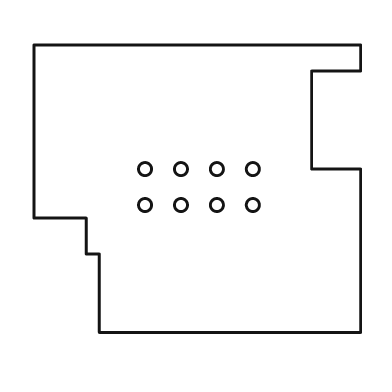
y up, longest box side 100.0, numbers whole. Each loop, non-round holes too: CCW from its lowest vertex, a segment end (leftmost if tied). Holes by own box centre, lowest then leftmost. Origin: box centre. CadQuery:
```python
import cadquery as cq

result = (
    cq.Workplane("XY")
    .moveTo(-30.0, -44.0)
    .lineTo(50.0, -44.0)
    .lineTo(50.0, 6.0)
    .lineTo(35.0, 6.0)
    .lineTo(35.0, 36.0)
    .lineTo(50.0, 36.0)
    .lineTo(50.0, 44.0)
    .lineTo(-50.0, 44.0)
    .lineTo(-50.0, -9.0)
    .lineTo(-34.0, -9.0)
    .lineTo(-34.0, -20.0)
    .lineTo(-30.0, -20.0)
    .close()
    .moveTo(-16.0, -5.0)
    .circle(2.0)
    .moveTo(-5.0, -5.0)
    .circle(2.0)
    .moveTo(6.0, -5.0)
    .circle(2.0)
    .moveTo(17.0, -5.0)
    .circle(2.0)
    .moveTo(-16.0, 6.0)
    .circle(2.0)
    .moveTo(-5.0, 6.0)
    .circle(2.0)
    .moveTo(6.0, 6.0)
    .circle(2.0)
    .moveTo(17.0, 6.0)
    .circle(2.0)
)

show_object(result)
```